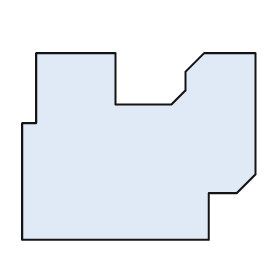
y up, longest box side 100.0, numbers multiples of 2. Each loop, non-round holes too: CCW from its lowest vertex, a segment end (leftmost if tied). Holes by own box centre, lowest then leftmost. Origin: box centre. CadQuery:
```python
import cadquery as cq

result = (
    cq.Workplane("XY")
    .moveTo(-50.0, -40.0)
    .lineTo(30.0, -40.0)
    .lineTo(30.0, -20.0)
    .lineTo(42.0, -20.0)
    .lineTo(50.0, -12.0)
    .lineTo(50.0, 40.0)
    .lineTo(28.0, 40.0)
    .lineTo(20.0, 32.0)
    .lineTo(20.0, 24.0)
    .lineTo(14.0, 18.0)
    .lineTo(-10.0, 18.0)
    .lineTo(-10.0, 40.0)
    .lineTo(-44.0, 40.0)
    .lineTo(-44.0, 10.0)
    .lineTo(-50.0, 10.0)
    .close()
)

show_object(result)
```